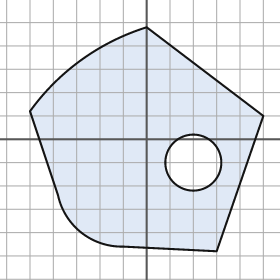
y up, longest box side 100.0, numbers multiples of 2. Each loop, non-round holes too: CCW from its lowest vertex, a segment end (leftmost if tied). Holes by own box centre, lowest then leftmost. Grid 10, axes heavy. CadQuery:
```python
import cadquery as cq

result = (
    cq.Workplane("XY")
    .moveTo(30.0, -48.0)
    .lineTo(50.0, 10.0)
    .lineTo(0.0, 48.0)
    .threePointArc((-28.0, 34.0), (-50.0, 12.0))
    .lineTo(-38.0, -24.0)
    .threePointArc((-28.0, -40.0), (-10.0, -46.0))
    .close()
    .moveTo(20.0, -10.0)
    .circle(12.0)
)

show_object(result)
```